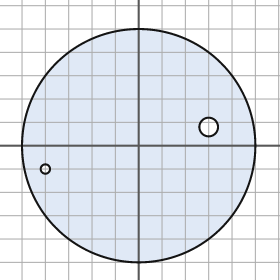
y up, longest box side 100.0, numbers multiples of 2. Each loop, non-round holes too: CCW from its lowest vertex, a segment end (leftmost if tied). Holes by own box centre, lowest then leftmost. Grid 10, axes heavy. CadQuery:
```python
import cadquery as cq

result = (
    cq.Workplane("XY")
    .moveTo(0.0, 0.0)
    .circle(50.0)
    .moveTo(-40.0, -10.0)
    .circle(2.0)
    .moveTo(30.0, 8.0)
    .circle(4.0)
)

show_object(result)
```